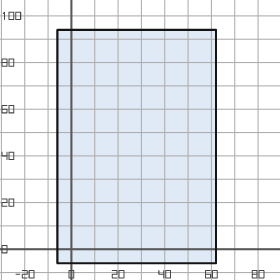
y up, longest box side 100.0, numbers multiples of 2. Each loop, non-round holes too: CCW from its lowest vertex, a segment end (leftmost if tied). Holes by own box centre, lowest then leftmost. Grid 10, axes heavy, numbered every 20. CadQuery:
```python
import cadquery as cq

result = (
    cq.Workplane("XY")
    .moveTo(-6.0, -6.0)
    .lineTo(62.0, -6.0)
    .lineTo(62.0, 94.0)
    .lineTo(-6.0, 94.0)
    .close()
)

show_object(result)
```